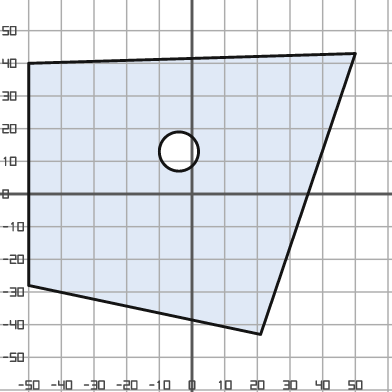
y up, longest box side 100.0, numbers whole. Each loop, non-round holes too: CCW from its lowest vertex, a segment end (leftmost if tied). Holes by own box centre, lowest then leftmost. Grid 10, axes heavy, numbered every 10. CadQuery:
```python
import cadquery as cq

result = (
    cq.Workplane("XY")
    .moveTo(21.0, -43.0)
    .lineTo(50.0, 43.0)
    .lineTo(-50.0, 40.0)
    .lineTo(-50.0, -28.0)
    .close()
    .moveTo(-4.0, 13.0)
    .circle(6.0)
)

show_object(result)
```